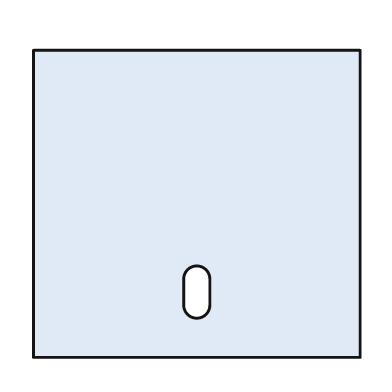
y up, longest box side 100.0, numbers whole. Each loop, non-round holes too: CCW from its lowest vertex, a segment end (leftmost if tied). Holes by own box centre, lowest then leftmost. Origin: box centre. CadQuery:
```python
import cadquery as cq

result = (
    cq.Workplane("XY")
    .moveTo(-50.0, -47.0)
    .lineTo(50.0, -47.0)
    .lineTo(50.0, 47.0)
    .lineTo(-50.0, 47.0)
    .close()
    .moveTo(-4.0, -31.0)
    .threePointArc((0.0, -35.0), (4.0, -31.0))
    .lineTo(4.0, -23.0)
    .threePointArc((0.0, -19.0), (-4.0, -23.0))
    .close()
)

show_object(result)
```